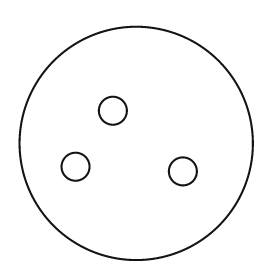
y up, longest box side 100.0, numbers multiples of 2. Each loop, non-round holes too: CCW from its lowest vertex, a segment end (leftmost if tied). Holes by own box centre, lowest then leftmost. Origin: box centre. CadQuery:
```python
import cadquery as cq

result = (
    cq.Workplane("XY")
    .moveTo(0.0, 0.0)
    .circle(50.0)
    .moveTo(20.0, -12.0)
    .circle(6.0)
    .moveTo(-26.0, -10.0)
    .circle(6.0)
    .moveTo(-10.0, 14.0)
    .circle(6.0)
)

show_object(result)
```